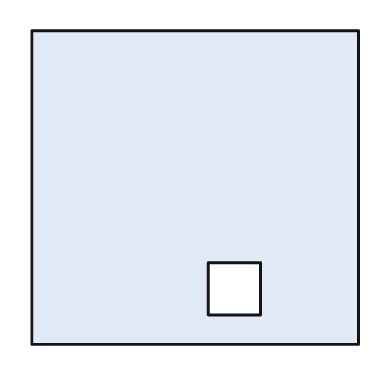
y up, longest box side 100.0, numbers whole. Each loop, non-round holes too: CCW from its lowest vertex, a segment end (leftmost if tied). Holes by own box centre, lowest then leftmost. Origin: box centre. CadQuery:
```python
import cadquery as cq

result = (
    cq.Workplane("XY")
    .moveTo(-50.0, -48.0)
    .lineTo(50.0, -48.0)
    .lineTo(50.0, 48.0)
    .lineTo(-50.0, 48.0)
    .close()
    .moveTo(4.0, -39.0)
    .lineTo(20.0, -39.0)
    .lineTo(20.0, -23.0)
    .lineTo(4.0, -23.0)
    .close()
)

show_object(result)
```